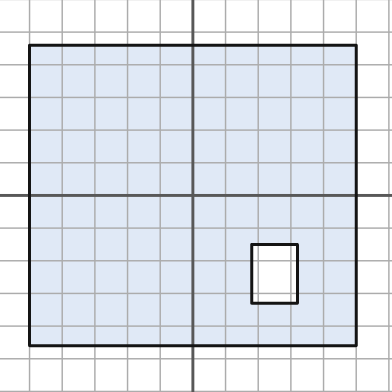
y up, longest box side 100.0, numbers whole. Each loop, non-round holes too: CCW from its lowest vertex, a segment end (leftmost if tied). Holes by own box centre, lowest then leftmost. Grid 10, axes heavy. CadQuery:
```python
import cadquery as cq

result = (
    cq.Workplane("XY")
    .moveTo(-50.0, -46.0)
    .lineTo(50.0, -46.0)
    .lineTo(50.0, 46.0)
    .lineTo(-50.0, 46.0)
    .close()
    .moveTo(18.0, -33.0)
    .lineTo(32.0, -33.0)
    .lineTo(32.0, -15.0)
    .lineTo(18.0, -15.0)
    .close()
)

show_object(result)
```